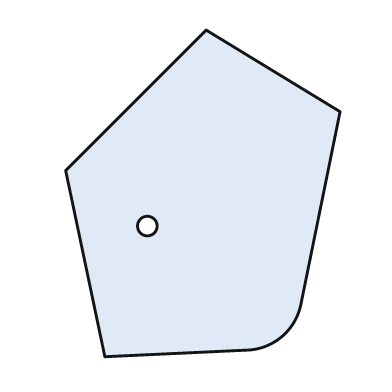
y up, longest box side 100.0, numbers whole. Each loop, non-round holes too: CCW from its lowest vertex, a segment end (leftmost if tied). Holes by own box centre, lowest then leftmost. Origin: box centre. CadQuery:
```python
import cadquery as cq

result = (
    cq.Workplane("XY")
    .moveTo(-30.0, -50.0)
    .lineTo(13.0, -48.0)
    .threePointArc((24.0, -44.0), (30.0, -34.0))
    .lineTo(42.0, 25.0)
    .lineTo(1.0, 50.0)
    .lineTo(-42.0, 7.0)
    .close()
    .moveTo(-17.0, -10.0)
    .circle(3.0)
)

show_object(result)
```